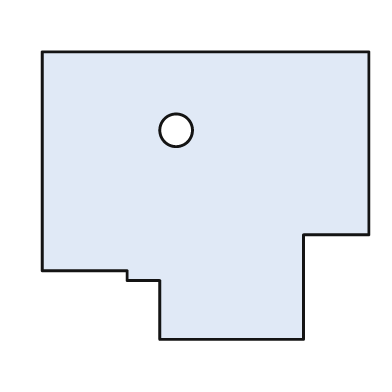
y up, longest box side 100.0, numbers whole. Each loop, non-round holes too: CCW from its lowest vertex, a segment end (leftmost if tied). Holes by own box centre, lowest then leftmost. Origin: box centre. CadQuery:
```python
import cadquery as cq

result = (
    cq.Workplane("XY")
    .moveTo(-14.0, -44.0)
    .lineTo(30.0, -44.0)
    .lineTo(30.0, -12.0)
    .lineTo(50.0, -12.0)
    .lineTo(50.0, 44.0)
    .lineTo(-50.0, 44.0)
    .lineTo(-50.0, -23.0)
    .lineTo(-24.0, -23.0)
    .lineTo(-24.0, -26.0)
    .lineTo(-14.0, -26.0)
    .close()
    .moveTo(-9.0, 20.0)
    .circle(5.0)
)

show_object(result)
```